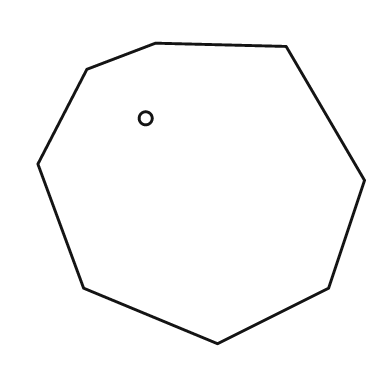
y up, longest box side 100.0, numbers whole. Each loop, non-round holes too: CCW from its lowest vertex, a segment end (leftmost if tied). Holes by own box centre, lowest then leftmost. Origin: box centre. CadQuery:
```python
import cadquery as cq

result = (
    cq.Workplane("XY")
    .moveTo(5.0, -46.0)
    .lineTo(39.0, -29.0)
    .lineTo(50.0, 4.0)
    .lineTo(26.0, 45.0)
    .lineTo(-14.0, 46.0)
    .lineTo(-35.0, 38.0)
    .lineTo(-50.0, 9.0)
    .lineTo(-36.0, -29.0)
    .close()
    .moveTo(-17.0, 23.0)
    .circle(2.0)
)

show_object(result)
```